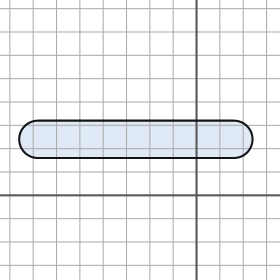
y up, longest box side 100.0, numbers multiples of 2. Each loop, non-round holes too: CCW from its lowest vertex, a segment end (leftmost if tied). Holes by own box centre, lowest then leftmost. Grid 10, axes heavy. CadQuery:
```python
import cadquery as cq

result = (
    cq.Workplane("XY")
    .moveTo(-68.0, 16.0)
    .lineTo(16.0, 16.0)
    .threePointArc((24.0, 24.0), (16.0, 32.0))
    .lineTo(-68.0, 32.0)
    .threePointArc((-76.0, 24.0), (-68.0, 16.0))
    .close()
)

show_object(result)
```